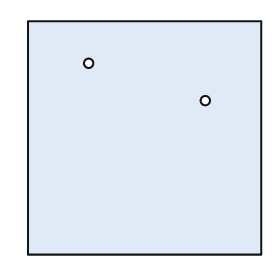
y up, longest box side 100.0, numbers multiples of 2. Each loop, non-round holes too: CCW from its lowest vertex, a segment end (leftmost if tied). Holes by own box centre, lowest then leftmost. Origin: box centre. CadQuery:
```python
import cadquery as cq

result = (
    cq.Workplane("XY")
    .moveTo(-50.0, -50.0)
    .lineTo(50.0, -50.0)
    .lineTo(50.0, 50.0)
    .lineTo(-50.0, 50.0)
    .close()
    .moveTo(26.0, 16.0)
    .circle(2.0)
    .moveTo(-24.0, 32.0)
    .circle(2.0)
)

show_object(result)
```